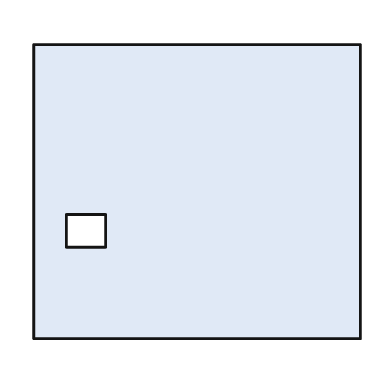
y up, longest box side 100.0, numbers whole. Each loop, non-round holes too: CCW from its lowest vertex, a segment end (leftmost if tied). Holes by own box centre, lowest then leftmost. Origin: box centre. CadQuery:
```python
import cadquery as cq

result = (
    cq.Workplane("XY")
    .moveTo(-50.0, -45.0)
    .lineTo(50.0, -45.0)
    .lineTo(50.0, 45.0)
    .lineTo(-50.0, 45.0)
    .close()
    .moveTo(-40.0, -17.0)
    .lineTo(-28.0, -17.0)
    .lineTo(-28.0, -7.0)
    .lineTo(-40.0, -7.0)
    .close()
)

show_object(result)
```